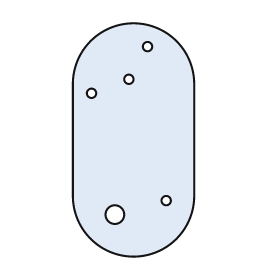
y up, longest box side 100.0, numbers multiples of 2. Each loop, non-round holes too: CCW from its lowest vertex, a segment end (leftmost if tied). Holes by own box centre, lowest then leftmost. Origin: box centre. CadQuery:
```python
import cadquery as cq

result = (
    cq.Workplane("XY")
    .moveTo(-26.0, -24.0)
    .threePointArc((0.0, -50.0), (26.0, -24.0))
    .lineTo(26.0, 24.0)
    .threePointArc((0.0, 50.0), (-26.0, 24.0))
    .close()
    .moveTo(-8.0, -32.0)
    .circle(4.0)
    .moveTo(14.0, -26.0)
    .circle(2.0)
    .moveTo(-18.0, 20.0)
    .circle(2.0)
    .moveTo(-2.0, 26.0)
    .circle(2.0)
    .moveTo(6.0, 40.0)
    .circle(2.0)
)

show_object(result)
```